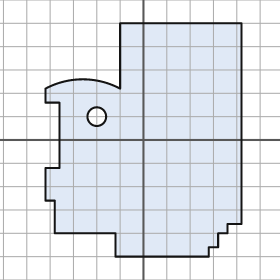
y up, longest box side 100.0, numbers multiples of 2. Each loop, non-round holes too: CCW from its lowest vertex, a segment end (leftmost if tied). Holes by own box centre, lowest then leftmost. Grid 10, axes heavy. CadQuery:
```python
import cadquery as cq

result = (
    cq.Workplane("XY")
    .moveTo(-12.0, -50.0)
    .lineTo(28.0, -50.0)
    .lineTo(28.0, -46.0)
    .lineTo(32.0, -46.0)
    .lineTo(32.0, -40.0)
    .lineTo(36.0, -40.0)
    .lineTo(36.0, -36.0)
    .lineTo(42.0, -36.0)
    .lineTo(42.0, 50.0)
    .lineTo(-10.0, 50.0)
    .lineTo(-10.0, 22.0)
    .threePointArc((-26.0, 26.0), (-42.0, 22.0))
    .lineTo(-42.0, 16.0)
    .lineTo(-36.0, 16.0)
    .lineTo(-36.0, -12.0)
    .lineTo(-42.0, -12.0)
    .lineTo(-42.0, -26.0)
    .lineTo(-38.0, -26.0)
    .lineTo(-38.0, -40.0)
    .lineTo(-12.0, -40.0)
    .close()
    .moveTo(-20.0, 10.0)
    .circle(4.0)
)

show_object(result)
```